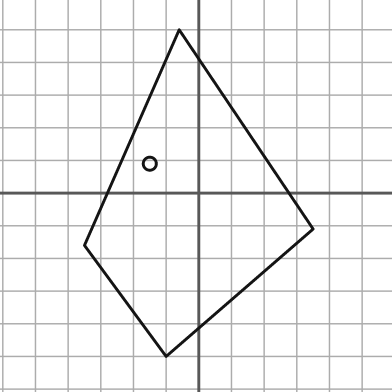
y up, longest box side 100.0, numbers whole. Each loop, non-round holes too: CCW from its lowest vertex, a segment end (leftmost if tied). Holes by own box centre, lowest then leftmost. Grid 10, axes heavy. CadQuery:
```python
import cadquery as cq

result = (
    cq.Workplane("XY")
    .moveTo(-10.0, -50.0)
    .lineTo(35.0, -11.0)
    .lineTo(-6.0, 50.0)
    .lineTo(-35.0, -16.0)
    .close()
    .moveTo(-15.0, 9.0)
    .circle(2.0)
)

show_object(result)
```